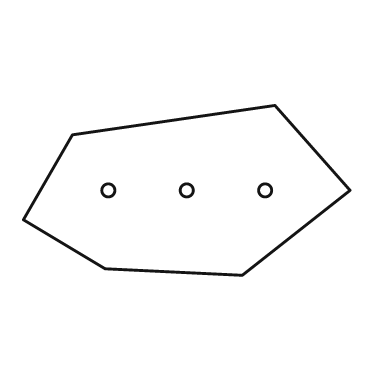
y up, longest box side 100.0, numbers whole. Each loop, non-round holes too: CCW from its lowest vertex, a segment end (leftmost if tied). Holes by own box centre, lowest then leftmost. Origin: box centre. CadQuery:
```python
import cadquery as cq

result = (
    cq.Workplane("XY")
    .moveTo(17.0, -26.0)
    .lineTo(50.0, 0.0)
    .lineTo(27.0, 26.0)
    .lineTo(-35.0, 17.0)
    .lineTo(-50.0, -9.0)
    .lineTo(-25.0, -24.0)
    .close()
    .moveTo(-24.0, 0.0)
    .circle(2.0)
    .moveTo(0.0, 0.0)
    .circle(2.0)
    .moveTo(24.0, 0.0)
    .circle(2.0)
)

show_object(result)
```